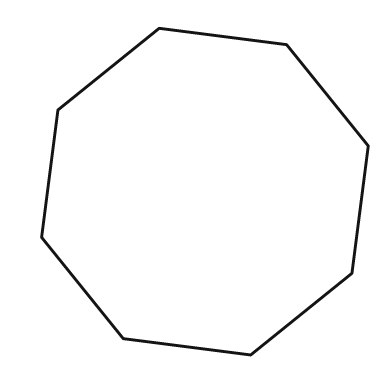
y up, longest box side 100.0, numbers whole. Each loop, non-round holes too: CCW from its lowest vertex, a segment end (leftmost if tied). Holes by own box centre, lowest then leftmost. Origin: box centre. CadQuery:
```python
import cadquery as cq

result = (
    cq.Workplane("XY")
    .moveTo(14.0, -50.0)
    .lineTo(45.0, -25.0)
    .lineTo(50.0, 14.0)
    .lineTo(25.0, 45.0)
    .lineTo(-14.0, 50.0)
    .lineTo(-45.0, 25.0)
    .lineTo(-50.0, -14.0)
    .lineTo(-25.0, -45.0)
    .close()
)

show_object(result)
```